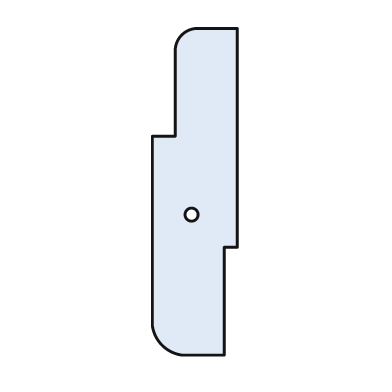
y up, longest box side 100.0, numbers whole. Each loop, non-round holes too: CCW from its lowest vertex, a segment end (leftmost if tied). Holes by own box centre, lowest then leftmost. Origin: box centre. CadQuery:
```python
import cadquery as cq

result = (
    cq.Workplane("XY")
    .moveTo(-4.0, -50.0)
    .lineTo(9.0, -50.0)
    .lineTo(9.0, -17.0)
    .lineTo(13.0, -17.0)
    .lineTo(13.0, 50.0)
    .lineTo(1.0, 50.0)
    .threePointArc((-4.0, 48.0), (-6.0, 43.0))
    .lineTo(-6.0, 17.0)
    .lineTo(-13.0, 17.0)
    .lineTo(-13.0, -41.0)
    .threePointArc((-10.0, -47.0), (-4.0, -50.0))
    .close()
    .moveTo(-1.0, -7.0)
    .circle(2.0)
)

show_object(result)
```